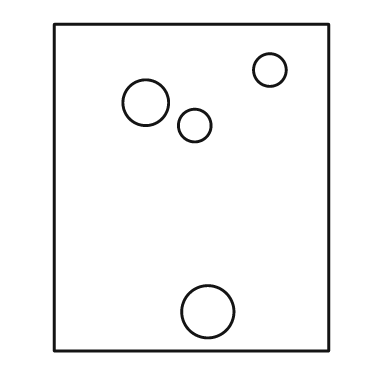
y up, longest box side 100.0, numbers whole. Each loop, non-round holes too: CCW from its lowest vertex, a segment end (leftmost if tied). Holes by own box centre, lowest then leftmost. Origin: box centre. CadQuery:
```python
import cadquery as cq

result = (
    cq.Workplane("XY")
    .moveTo(-42.0, -50.0)
    .lineTo(42.0, -50.0)
    .lineTo(42.0, 50.0)
    .lineTo(-42.0, 50.0)
    .close()
    .moveTo(5.0, -38.0)
    .circle(8.0)
    .moveTo(1.0, 19.0)
    .circle(5.0)
    .moveTo(-14.0, 26.0)
    .circle(7.0)
    .moveTo(24.0, 36.0)
    .circle(5.0)
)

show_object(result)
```